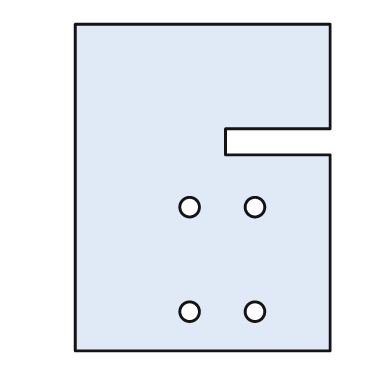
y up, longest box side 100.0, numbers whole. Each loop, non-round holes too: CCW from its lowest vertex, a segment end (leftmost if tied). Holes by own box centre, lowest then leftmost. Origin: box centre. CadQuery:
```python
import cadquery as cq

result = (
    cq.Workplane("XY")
    .moveTo(-39.0, -50.0)
    .lineTo(39.0, -50.0)
    .lineTo(39.0, 10.0)
    .lineTo(7.0, 10.0)
    .lineTo(7.0, 18.0)
    .lineTo(39.0, 18.0)
    .lineTo(39.0, 50.0)
    .lineTo(-39.0, 50.0)
    .close()
    .moveTo(-4.0, -38.0)
    .circle(3.0)
    .moveTo(16.0, -38.0)
    .circle(3.0)
    .moveTo(-4.0, -6.0)
    .circle(3.0)
    .moveTo(16.0, -6.0)
    .circle(3.0)
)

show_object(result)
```